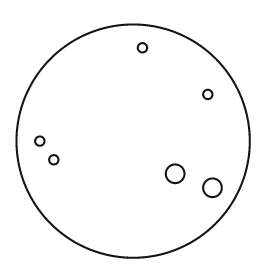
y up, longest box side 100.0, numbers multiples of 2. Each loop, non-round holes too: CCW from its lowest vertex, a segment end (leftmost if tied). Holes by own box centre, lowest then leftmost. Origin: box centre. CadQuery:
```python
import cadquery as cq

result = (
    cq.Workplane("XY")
    .moveTo(0.0, 0.0)
    .circle(50.0)
    .moveTo(34.0, -20.0)
    .circle(4.0)
    .moveTo(18.0, -14.0)
    .circle(4.0)
    .moveTo(-34.0, -8.0)
    .circle(2.0)
    .moveTo(-40.0, 0.0)
    .circle(2.0)
    .moveTo(32.0, 20.0)
    .circle(2.0)
    .moveTo(4.0, 40.0)
    .circle(2.0)
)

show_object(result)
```